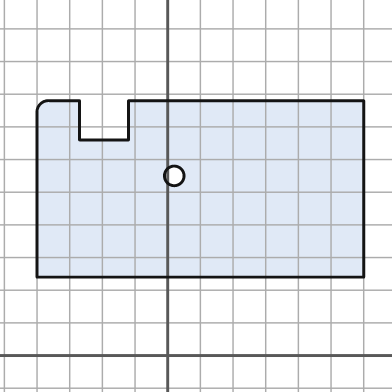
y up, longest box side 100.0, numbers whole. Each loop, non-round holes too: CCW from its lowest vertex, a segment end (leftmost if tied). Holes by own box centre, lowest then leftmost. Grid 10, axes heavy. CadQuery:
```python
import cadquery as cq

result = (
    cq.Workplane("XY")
    .moveTo(-40.0, 24.0)
    .lineTo(60.0, 24.0)
    .lineTo(60.0, 78.0)
    .lineTo(-12.0, 78.0)
    .lineTo(-12.0, 66.0)
    .lineTo(-27.0, 66.0)
    .lineTo(-27.0, 78.0)
    .lineTo(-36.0, 78.0)
    .threePointArc((-39.0, 77.0), (-40.0, 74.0))
    .close()
    .moveTo(2.0, 55.0)
    .circle(3.0)
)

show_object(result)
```